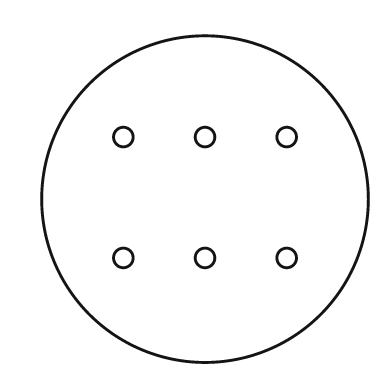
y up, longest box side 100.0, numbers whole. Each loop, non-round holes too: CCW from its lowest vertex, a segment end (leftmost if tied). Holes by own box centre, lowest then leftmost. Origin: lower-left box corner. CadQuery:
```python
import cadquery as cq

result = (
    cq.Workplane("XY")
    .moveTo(50.0, 50.0)
    .circle(50.0)
    .moveTo(25.0, 32.0)
    .circle(3.0)
    .moveTo(50.0, 32.0)
    .circle(3.0)
    .moveTo(75.0, 32.0)
    .circle(3.0)
    .moveTo(25.0, 69.0)
    .circle(3.0)
    .moveTo(50.0, 69.0)
    .circle(3.0)
    .moveTo(75.0, 69.0)
    .circle(3.0)
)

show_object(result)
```